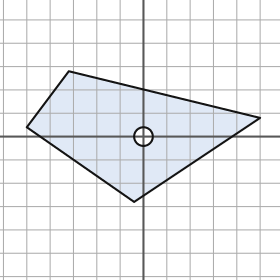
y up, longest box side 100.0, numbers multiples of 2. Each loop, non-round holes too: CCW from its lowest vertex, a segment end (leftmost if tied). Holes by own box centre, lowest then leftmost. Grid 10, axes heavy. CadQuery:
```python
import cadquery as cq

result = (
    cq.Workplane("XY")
    .moveTo(-4.0, -28.0)
    .lineTo(50.0, 8.0)
    .lineTo(-32.0, 28.0)
    .lineTo(-50.0, 4.0)
    .close()
    .moveTo(0.0, 0.0)
    .circle(4.0)
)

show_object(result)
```